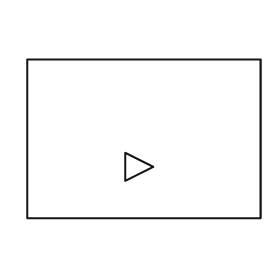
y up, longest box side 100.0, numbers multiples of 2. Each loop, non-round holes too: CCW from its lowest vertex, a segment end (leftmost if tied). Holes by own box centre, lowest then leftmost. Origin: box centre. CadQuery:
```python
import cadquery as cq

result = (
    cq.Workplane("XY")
    .moveTo(-50.0, -34.0)
    .lineTo(50.0, -34.0)
    .lineTo(50.0, 34.0)
    .lineTo(-50.0, 34.0)
    .close()
    .moveTo(-8.0, -18.0)
    .lineTo(4.0, -12.0)
    .lineTo(-8.0, -6.0)
    .close()
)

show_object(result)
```